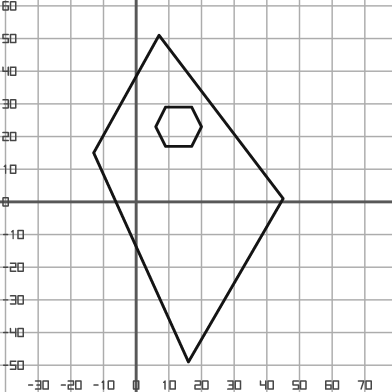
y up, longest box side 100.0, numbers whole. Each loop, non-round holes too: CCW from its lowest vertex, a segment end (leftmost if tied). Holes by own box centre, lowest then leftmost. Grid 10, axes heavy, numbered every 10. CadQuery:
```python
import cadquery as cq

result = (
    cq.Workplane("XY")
    .moveTo(16.0, -49.0)
    .lineTo(45.0, 1.0)
    .lineTo(7.0, 51.0)
    .lineTo(-13.0, 15.0)
    .close()
    .moveTo(9.0, 17.0)
    .lineTo(17.0, 17.0)
    .lineTo(20.0, 23.0)
    .lineTo(17.0, 29.0)
    .lineTo(9.0, 29.0)
    .lineTo(6.0, 23.0)
    .close()
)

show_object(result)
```